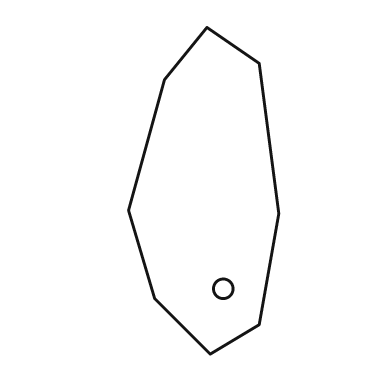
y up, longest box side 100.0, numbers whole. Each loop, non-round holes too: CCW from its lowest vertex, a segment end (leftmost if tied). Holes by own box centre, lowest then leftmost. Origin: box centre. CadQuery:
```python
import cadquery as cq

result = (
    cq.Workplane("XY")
    .moveTo(2.0, -50.0)
    .lineTo(17.0, -41.0)
    .lineTo(23.0, -7.0)
    .lineTo(17.0, 39.0)
    .lineTo(1.0, 50.0)
    .lineTo(-12.0, 34.0)
    .lineTo(-23.0, -6.0)
    .lineTo(-15.0, -33.0)
    .close()
    .moveTo(6.0, -30.0)
    .circle(3.0)
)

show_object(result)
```